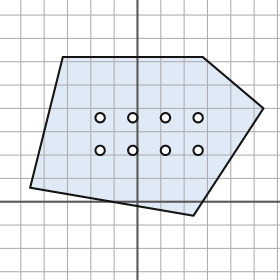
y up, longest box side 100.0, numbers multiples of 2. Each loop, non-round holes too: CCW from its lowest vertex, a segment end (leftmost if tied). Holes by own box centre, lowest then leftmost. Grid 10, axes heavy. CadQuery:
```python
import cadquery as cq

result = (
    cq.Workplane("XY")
    .moveTo(24.0, -6.0)
    .lineTo(54.0, 40.0)
    .lineTo(28.0, 62.0)
    .lineTo(-32.0, 62.0)
    .lineTo(-46.0, 6.0)
    .close()
    .moveTo(-16.0, 22.0)
    .circle(2.0)
    .moveTo(-2.0, 22.0)
    .circle(2.0)
    .moveTo(12.0, 22.0)
    .circle(2.0)
    .moveTo(26.0, 22.0)
    .circle(2.0)
    .moveTo(-16.0, 36.0)
    .circle(2.0)
    .moveTo(-2.0, 36.0)
    .circle(2.0)
    .moveTo(12.0, 36.0)
    .circle(2.0)
    .moveTo(26.0, 36.0)
    .circle(2.0)
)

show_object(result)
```